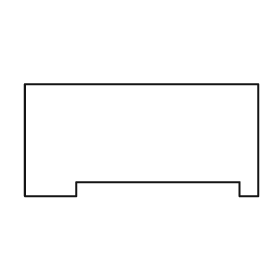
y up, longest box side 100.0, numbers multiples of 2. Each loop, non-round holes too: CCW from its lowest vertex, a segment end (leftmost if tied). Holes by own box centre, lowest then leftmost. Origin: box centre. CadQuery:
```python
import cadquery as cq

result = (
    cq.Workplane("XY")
    .moveTo(-50.0, -24.0)
    .lineTo(-28.0, -24.0)
    .lineTo(-28.0, -18.0)
    .lineTo(42.0, -18.0)
    .lineTo(42.0, -24.0)
    .lineTo(50.0, -24.0)
    .lineTo(50.0, 24.0)
    .lineTo(-50.0, 24.0)
    .close()
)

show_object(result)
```